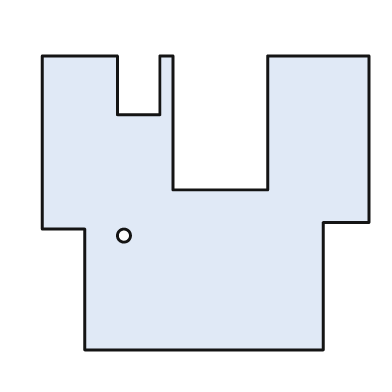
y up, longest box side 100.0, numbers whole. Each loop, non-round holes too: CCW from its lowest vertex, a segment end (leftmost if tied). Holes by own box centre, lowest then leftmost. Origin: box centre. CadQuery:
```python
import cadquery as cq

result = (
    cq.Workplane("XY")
    .moveTo(-37.0, -45.0)
    .lineTo(36.0, -45.0)
    .lineTo(36.0, -6.0)
    .lineTo(50.0, -6.0)
    .lineTo(50.0, 45.0)
    .lineTo(19.0, 45.0)
    .lineTo(19.0, 4.0)
    .lineTo(-10.0, 4.0)
    .lineTo(-10.0, 45.0)
    .lineTo(-14.0, 45.0)
    .lineTo(-14.0, 27.0)
    .lineTo(-27.0, 27.0)
    .lineTo(-27.0, 45.0)
    .lineTo(-50.0, 45.0)
    .lineTo(-50.0, -8.0)
    .lineTo(-37.0, -8.0)
    .close()
    .moveTo(-25.0, -10.0)
    .circle(2.0)
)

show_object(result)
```